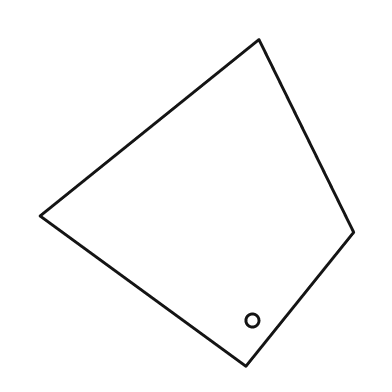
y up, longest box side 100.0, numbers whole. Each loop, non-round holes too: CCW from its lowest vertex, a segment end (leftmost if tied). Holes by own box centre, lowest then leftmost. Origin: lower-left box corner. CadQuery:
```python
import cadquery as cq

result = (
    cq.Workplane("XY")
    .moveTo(63.0, 0.0)
    .lineTo(96.0, 41.0)
    .lineTo(67.0, 100.0)
    .lineTo(0.0, 46.0)
    .close()
    .moveTo(65.0, 14.0)
    .circle(2.0)
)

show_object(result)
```